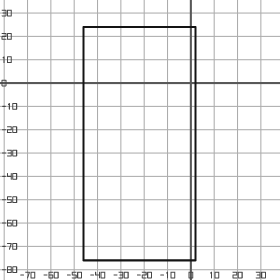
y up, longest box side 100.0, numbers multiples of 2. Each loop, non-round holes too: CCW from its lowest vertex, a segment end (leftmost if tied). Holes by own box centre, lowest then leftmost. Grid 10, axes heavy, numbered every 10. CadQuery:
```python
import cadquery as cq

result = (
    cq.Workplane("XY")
    .moveTo(-46.0, -76.0)
    .lineTo(2.0, -76.0)
    .lineTo(2.0, 24.0)
    .lineTo(-46.0, 24.0)
    .close()
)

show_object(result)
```